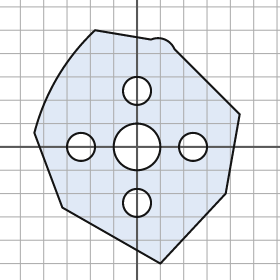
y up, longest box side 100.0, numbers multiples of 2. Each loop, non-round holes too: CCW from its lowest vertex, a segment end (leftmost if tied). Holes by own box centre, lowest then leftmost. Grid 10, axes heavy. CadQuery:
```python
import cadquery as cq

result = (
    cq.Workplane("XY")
    .moveTo(10.0, -50.0)
    .lineTo(38.0, -20.0)
    .lineTo(44.0, 14.0)
    .lineTo(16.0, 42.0)
    .threePointArc((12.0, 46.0), (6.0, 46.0))
    .lineTo(-18.0, 50.0)
    .threePointArc((-34.0, 30.0), (-44.0, 6.0))
    .lineTo(-32.0, -26.0)
    .close()
    .moveTo(0.0, -24.0)
    .circle(6.0)
    .moveTo(-24.0, 0.0)
    .circle(6.0)
    .moveTo(0.0, 0.0)
    .circle(10.0)
    .moveTo(24.0, 0.0)
    .circle(6.0)
    .moveTo(0.0, 24.0)
    .circle(6.0)
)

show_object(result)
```